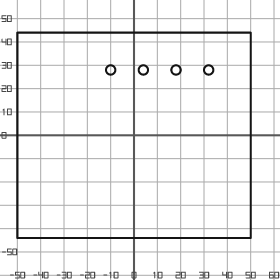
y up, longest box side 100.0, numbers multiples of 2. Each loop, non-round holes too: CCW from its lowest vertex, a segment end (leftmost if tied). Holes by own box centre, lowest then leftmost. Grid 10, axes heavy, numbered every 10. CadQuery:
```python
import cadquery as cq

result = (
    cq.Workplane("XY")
    .moveTo(-50.0, -44.0)
    .lineTo(50.0, -44.0)
    .lineTo(50.0, 44.0)
    .lineTo(-50.0, 44.0)
    .close()
    .moveTo(-10.0, 28.0)
    .circle(2.0)
    .moveTo(4.0, 28.0)
    .circle(2.0)
    .moveTo(18.0, 28.0)
    .circle(2.0)
    .moveTo(32.0, 28.0)
    .circle(2.0)
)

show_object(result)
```